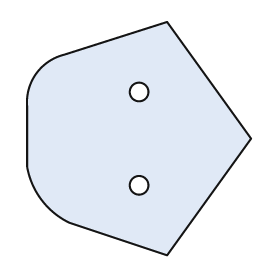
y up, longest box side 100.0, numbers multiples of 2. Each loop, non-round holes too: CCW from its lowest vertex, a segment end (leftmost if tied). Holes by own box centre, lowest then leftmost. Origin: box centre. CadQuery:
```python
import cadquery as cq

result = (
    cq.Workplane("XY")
    .moveTo(12.0, -50.0)
    .lineTo(48.0, 0.0)
    .lineTo(12.0, 50.0)
    .lineTo(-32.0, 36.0)
    .threePointArc((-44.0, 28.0), (-48.0, 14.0))
    .lineTo(-48.0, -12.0)
    .threePointArc((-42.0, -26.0), (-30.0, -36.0))
    .close()
    .moveTo(0.0, -20.0)
    .circle(4.0)
    .moveTo(0.0, 20.0)
    .circle(4.0)
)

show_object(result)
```